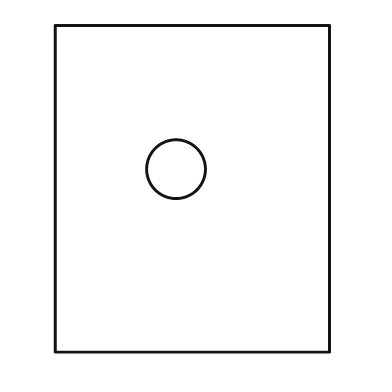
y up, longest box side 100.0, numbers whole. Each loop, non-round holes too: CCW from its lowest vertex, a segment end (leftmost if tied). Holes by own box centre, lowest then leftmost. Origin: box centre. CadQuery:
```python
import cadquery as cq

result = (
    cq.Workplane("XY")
    .moveTo(-42.0, -50.0)
    .lineTo(42.0, -50.0)
    .lineTo(42.0, 50.0)
    .lineTo(-42.0, 50.0)
    .close()
    .moveTo(-5.0, 6.0)
    .circle(9.0)
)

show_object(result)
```